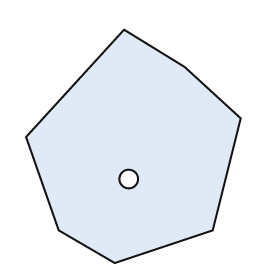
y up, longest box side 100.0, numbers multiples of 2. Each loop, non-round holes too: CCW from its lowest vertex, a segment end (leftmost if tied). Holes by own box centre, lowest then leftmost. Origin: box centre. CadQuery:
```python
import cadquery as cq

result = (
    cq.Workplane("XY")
    .moveTo(-8.0, -50.0)
    .lineTo(34.0, -36.0)
    .lineTo(46.0, 12.0)
    .lineTo(22.0, 34.0)
    .lineTo(-4.0, 50.0)
    .lineTo(-46.0, 4.0)
    .lineTo(-32.0, -36.0)
    .close()
    .moveTo(-2.0, -14.0)
    .circle(4.0)
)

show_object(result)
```